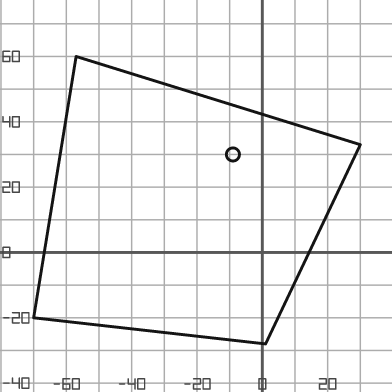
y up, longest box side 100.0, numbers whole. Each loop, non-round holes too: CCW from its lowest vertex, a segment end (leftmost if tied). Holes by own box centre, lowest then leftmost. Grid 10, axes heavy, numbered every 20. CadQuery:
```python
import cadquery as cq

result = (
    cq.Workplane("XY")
    .moveTo(1.0, -28.0)
    .lineTo(30.0, 33.0)
    .lineTo(-57.0, 60.0)
    .lineTo(-70.0, -20.0)
    .close()
    .moveTo(-9.0, 30.0)
    .circle(2.0)
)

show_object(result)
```